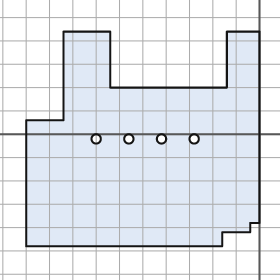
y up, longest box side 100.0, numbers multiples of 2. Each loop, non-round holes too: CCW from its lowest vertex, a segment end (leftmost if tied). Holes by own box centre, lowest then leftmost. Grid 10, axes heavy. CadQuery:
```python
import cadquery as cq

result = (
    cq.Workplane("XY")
    .moveTo(-100.0, -48.0)
    .lineTo(-16.0, -48.0)
    .lineTo(-16.0, -42.0)
    .lineTo(-4.0, -42.0)
    .lineTo(-4.0, -38.0)
    .lineTo(0.0, -38.0)
    .lineTo(0.0, 44.0)
    .lineTo(-14.0, 44.0)
    .lineTo(-14.0, 20.0)
    .lineTo(-64.0, 20.0)
    .lineTo(-64.0, 44.0)
    .lineTo(-84.0, 44.0)
    .lineTo(-84.0, 6.0)
    .lineTo(-100.0, 6.0)
    .close()
    .moveTo(-70.0, -2.0)
    .circle(2.0)
    .moveTo(-56.0, -2.0)
    .circle(2.0)
    .moveTo(-42.0, -2.0)
    .circle(2.0)
    .moveTo(-28.0, -2.0)
    .circle(2.0)
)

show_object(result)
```